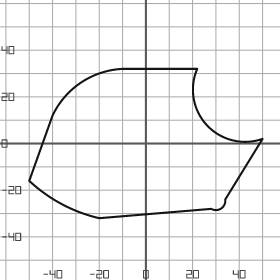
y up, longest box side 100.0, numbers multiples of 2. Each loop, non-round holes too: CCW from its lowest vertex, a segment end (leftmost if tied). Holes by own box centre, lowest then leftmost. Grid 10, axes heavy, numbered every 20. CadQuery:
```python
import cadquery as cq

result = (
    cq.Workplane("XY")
    .moveTo(-20.0, -32.0)
    .lineTo(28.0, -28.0)
    .threePointArc((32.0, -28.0), (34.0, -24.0))
    .lineTo(50.0, 2.0)
    .threePointArc((26.0, 8.0), (22.0, 32.0))
    .lineTo(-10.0, 32.0)
    .threePointArc((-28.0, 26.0), (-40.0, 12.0))
    .lineTo(-50.0, -16.0)
    .threePointArc((-36.0, -26.0), (-20.0, -32.0))
    .close()
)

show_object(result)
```